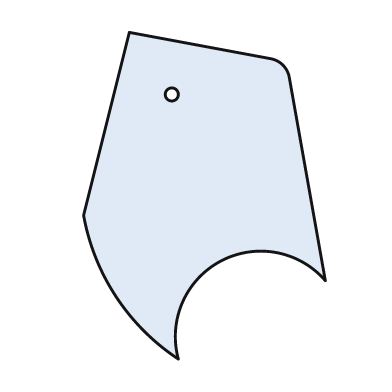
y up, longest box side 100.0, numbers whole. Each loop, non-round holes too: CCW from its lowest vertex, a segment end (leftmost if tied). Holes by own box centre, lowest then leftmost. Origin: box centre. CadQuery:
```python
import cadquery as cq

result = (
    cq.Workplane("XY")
    .moveTo(-8.0, -50.0)
    .threePointArc((5.0, -20.0), (37.0, -26.0))
    .lineTo(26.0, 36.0)
    .threePointArc((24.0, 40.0), (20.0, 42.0))
    .lineTo(-23.0, 50.0)
    .lineTo(-37.0, -6.0)
    .threePointArc((-27.0, -31.0), (-8.0, -50.0))
    .close()
    .moveTo(-10.0, 31.0)
    .circle(2.0)
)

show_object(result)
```